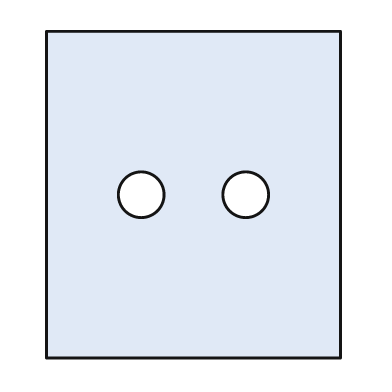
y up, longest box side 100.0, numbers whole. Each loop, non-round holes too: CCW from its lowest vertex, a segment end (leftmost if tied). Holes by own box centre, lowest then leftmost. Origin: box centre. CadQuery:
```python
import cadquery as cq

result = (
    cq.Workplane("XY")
    .moveTo(-45.0, -50.0)
    .lineTo(45.0, -50.0)
    .lineTo(45.0, 50.0)
    .lineTo(-45.0, 50.0)
    .close()
    .moveTo(-16.0, 0.0)
    .circle(7.0)
    .moveTo(16.0, 0.0)
    .circle(7.0)
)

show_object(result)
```